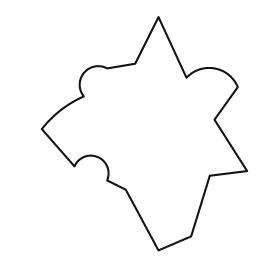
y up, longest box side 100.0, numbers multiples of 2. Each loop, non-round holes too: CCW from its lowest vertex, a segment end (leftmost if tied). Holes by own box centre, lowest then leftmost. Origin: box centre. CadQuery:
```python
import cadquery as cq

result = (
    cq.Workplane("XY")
    .moveTo(6.0, -50.0)
    .lineTo(20.0, -44.0)
    .lineTo(28.0, -18.0)
    .lineTo(44.0, -16.0)
    .lineTo(30.0, 6.0)
    .lineTo(40.0, 20.0)
    .threePointArc((30.0, 28.0), (18.0, 24.0))
    .lineTo(6.0, 50.0)
    .lineTo(-4.0, 30.0)
    .lineTo(-16.0, 28.0)
    .threePointArc((-26.0, 26.0), (-26.0, 16.0))
    .threePointArc((-36.0, 10.0), (-44.0, 2.0))
    .lineTo(-30.0, -14.0)
    .threePointArc((-20.0, -10.0), (-16.0, -20.0))
    .lineTo(-8.0, -24.0)
    .close()
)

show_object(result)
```